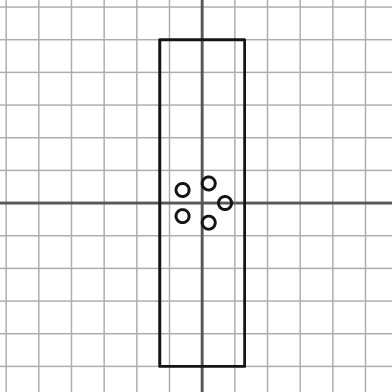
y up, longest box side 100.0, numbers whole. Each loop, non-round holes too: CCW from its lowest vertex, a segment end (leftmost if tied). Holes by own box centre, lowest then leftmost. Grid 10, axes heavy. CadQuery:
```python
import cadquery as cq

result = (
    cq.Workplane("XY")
    .moveTo(-13.0, -50.0)
    .lineTo(13.0, -50.0)
    .lineTo(13.0, 50.0)
    .lineTo(-13.0, 50.0)
    .close()
    .moveTo(2.0, -6.0)
    .circle(2.0)
    .moveTo(-6.0, -4.0)
    .circle(2.0)
    .moveTo(7.0, 0.0)
    .circle(2.0)
    .moveTo(-6.0, 4.0)
    .circle(2.0)
    .moveTo(2.0, 6.0)
    .circle(2.0)
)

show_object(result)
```